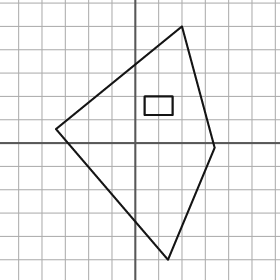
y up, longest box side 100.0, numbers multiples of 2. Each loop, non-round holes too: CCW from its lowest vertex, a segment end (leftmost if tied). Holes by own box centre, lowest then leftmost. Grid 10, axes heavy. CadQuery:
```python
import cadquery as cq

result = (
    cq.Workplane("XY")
    .moveTo(14.0, -50.0)
    .lineTo(34.0, -2.0)
    .lineTo(20.0, 50.0)
    .lineTo(-34.0, 6.0)
    .close()
    .moveTo(4.0, 12.0)
    .lineTo(16.0, 12.0)
    .lineTo(16.0, 20.0)
    .lineTo(4.0, 20.0)
    .close()
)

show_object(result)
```